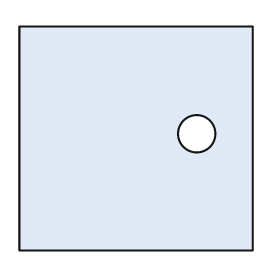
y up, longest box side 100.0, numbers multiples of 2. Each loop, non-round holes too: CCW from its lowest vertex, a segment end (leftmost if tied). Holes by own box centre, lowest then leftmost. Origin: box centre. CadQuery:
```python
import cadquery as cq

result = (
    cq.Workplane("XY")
    .moveTo(-50.0, -48.0)
    .lineTo(50.0, -48.0)
    .lineTo(50.0, 48.0)
    .lineTo(-50.0, 48.0)
    .close()
    .moveTo(26.0, 2.0)
    .circle(8.0)
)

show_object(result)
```